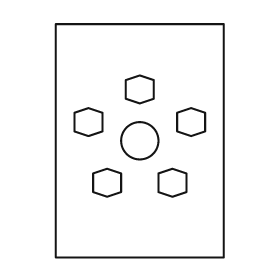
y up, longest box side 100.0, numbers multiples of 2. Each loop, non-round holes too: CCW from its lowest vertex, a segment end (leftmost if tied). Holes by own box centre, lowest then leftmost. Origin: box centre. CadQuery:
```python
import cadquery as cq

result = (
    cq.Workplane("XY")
    .moveTo(-36.0, -50.0)
    .lineTo(36.0, -50.0)
    .lineTo(36.0, 50.0)
    .lineTo(-36.0, 50.0)
    .close()
    .moveTo(-14.0, -24.0)
    .lineTo(-8.0, -22.0)
    .lineTo(-8.0, -14.0)
    .lineTo(-14.0, -12.0)
    .lineTo(-20.0, -14.0)
    .lineTo(-20.0, -22.0)
    .close()
    .moveTo(14.0, -24.0)
    .lineTo(20.0, -22.0)
    .lineTo(20.0, -14.0)
    .lineTo(14.0, -12.0)
    .lineTo(8.0, -14.0)
    .lineTo(8.0, -22.0)
    .close()
    .moveTo(0.0, 0.0)
    .circle(8.0)
    .moveTo(-22.0, 2.0)
    .lineTo(-16.0, 4.0)
    .lineTo(-16.0, 12.0)
    .lineTo(-22.0, 14.0)
    .lineTo(-28.0, 12.0)
    .lineTo(-28.0, 4.0)
    .close()
    .moveTo(22.0, 2.0)
    .lineTo(28.0, 4.0)
    .lineTo(28.0, 12.0)
    .lineTo(22.0, 14.0)
    .lineTo(16.0, 12.0)
    .lineTo(16.0, 4.0)
    .close()
    .moveTo(0.0, 16.0)
    .lineTo(6.0, 18.0)
    .lineTo(6.0, 26.0)
    .lineTo(0.0, 28.0)
    .lineTo(-6.0, 26.0)
    .lineTo(-6.0, 18.0)
    .close()
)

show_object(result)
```